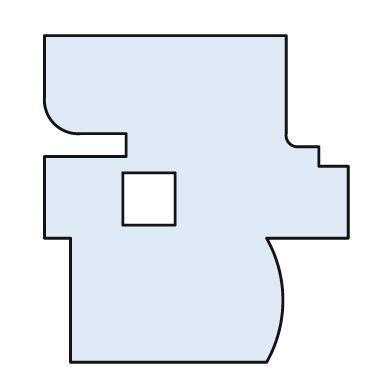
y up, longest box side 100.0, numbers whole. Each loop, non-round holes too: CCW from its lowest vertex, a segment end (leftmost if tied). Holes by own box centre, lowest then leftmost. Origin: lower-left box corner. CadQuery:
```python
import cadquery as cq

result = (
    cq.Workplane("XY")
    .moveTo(8.0, 0.0)
    .lineTo(68.0, 0.0)
    .threePointArc((73.0, 19.0), (68.0, 38.0))
    .lineTo(93.0, 38.0)
    .lineTo(93.0, 60.0)
    .lineTo(84.0, 60.0)
    .lineTo(84.0, 66.0)
    .lineTo(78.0, 66.0)
    .threePointArc((75.0, 67.0), (74.0, 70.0))
    .lineTo(74.0, 100.0)
    .lineTo(0.0, 100.0)
    .lineTo(0.0, 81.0)
    .threePointArc((3.0, 73.0), (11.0, 70.0))
    .lineTo(25.0, 70.0)
    .lineTo(25.0, 63.0)
    .lineTo(0.0, 63.0)
    .lineTo(0.0, 38.0)
    .lineTo(8.0, 38.0)
    .close()
    .moveTo(24.0, 42.0)
    .lineTo(40.0, 42.0)
    .lineTo(40.0, 58.0)
    .lineTo(24.0, 58.0)
    .close()
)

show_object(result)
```